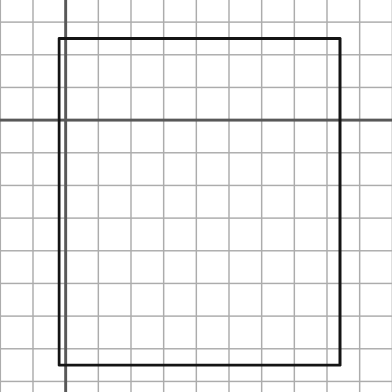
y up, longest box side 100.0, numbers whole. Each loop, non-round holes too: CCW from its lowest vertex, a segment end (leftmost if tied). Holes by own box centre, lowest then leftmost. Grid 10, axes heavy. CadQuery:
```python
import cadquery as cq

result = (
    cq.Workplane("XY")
    .moveTo(-2.0, -75.0)
    .lineTo(84.0, -75.0)
    .lineTo(84.0, 25.0)
    .lineTo(-2.0, 25.0)
    .close()
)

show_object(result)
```